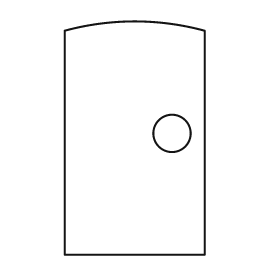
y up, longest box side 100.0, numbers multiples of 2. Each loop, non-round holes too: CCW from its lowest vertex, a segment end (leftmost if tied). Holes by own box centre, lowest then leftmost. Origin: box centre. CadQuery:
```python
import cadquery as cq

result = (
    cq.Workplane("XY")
    .moveTo(-30.0, -50.0)
    .lineTo(30.0, -50.0)
    .lineTo(30.0, 46.0)
    .threePointArc((0.0, 50.0), (-30.0, 46.0))
    .close()
    .moveTo(16.0, 2.0)
    .circle(8.0)
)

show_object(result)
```